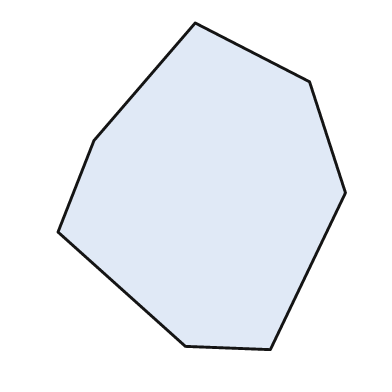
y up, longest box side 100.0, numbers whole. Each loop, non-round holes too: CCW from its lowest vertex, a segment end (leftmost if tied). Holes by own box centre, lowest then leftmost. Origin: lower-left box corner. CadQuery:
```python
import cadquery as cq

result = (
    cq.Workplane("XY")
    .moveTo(65.0, 0.0)
    .lineTo(88.0, 48.0)
    .lineTo(77.0, 82.0)
    .lineTo(42.0, 100.0)
    .lineTo(11.0, 64.0)
    .lineTo(0.0, 36.0)
    .lineTo(39.0, 1.0)
    .close()
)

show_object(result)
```